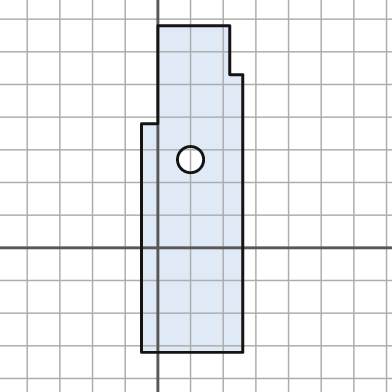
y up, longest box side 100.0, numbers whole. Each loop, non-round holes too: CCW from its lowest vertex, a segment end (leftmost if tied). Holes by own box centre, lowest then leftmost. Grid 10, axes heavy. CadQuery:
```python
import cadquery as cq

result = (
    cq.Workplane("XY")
    .moveTo(-5.0, -32.0)
    .lineTo(26.0, -32.0)
    .lineTo(26.0, 53.0)
    .lineTo(22.0, 53.0)
    .lineTo(22.0, 68.0)
    .lineTo(0.0, 68.0)
    .lineTo(0.0, 38.0)
    .lineTo(-5.0, 38.0)
    .close()
    .moveTo(10.0, 27.0)
    .circle(4.0)
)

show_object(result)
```